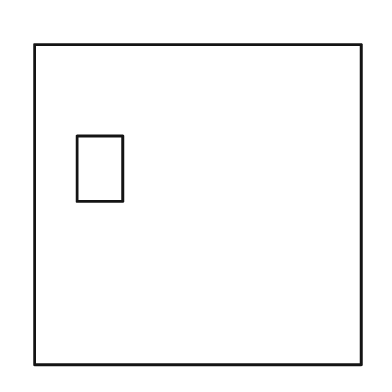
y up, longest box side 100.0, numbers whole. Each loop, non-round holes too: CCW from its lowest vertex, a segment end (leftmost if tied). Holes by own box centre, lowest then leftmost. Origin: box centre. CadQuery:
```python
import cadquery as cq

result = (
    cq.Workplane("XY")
    .moveTo(-50.0, -49.0)
    .lineTo(50.0, -49.0)
    .lineTo(50.0, 49.0)
    .lineTo(-50.0, 49.0)
    .close()
    .moveTo(-37.0, 1.0)
    .lineTo(-23.0, 1.0)
    .lineTo(-23.0, 21.0)
    .lineTo(-37.0, 21.0)
    .close()
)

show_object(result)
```